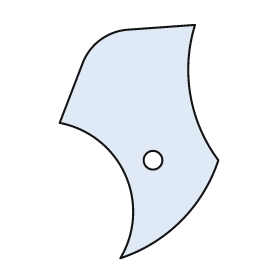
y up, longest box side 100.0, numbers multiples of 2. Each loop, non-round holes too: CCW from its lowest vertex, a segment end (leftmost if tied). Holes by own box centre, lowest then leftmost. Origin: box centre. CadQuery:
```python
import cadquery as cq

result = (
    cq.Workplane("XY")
    .moveTo(-8.0, -50.0)
    .threePointArc((18.0, -34.0), (34.0, -8.0))
    .threePointArc((22.0, 20.0), (24.0, 50.0))
    .lineTo(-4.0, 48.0)
    .threePointArc((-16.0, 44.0), (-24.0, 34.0))
    .lineTo(-34.0, 8.0)
    .threePointArc((-6.0, -14.0), (-8.0, -50.0))
    .close()
    .moveTo(6.0, -8.0)
    .circle(4.0)
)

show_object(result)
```